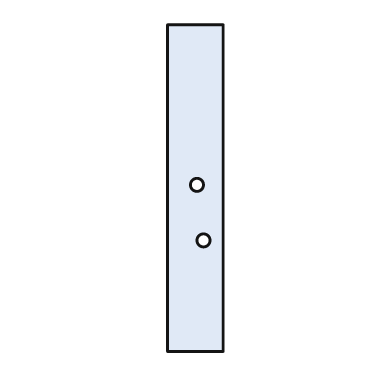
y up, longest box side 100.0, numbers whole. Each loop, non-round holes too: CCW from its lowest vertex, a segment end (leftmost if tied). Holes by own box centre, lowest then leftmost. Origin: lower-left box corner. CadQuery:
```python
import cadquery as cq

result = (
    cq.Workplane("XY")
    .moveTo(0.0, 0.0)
    .lineTo(17.0, 0.0)
    .lineTo(17.0, 100.0)
    .lineTo(0.0, 100.0)
    .close()
    .moveTo(11.0, 34.0)
    .circle(2.0)
    .moveTo(9.0, 51.0)
    .circle(2.0)
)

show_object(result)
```